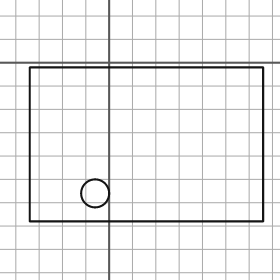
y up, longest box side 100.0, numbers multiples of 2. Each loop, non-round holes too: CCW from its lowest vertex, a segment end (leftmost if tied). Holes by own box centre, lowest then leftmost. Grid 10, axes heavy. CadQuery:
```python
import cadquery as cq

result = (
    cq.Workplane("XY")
    .moveTo(-34.0, -68.0)
    .lineTo(66.0, -68.0)
    .lineTo(66.0, -2.0)
    .lineTo(-34.0, -2.0)
    .close()
    .moveTo(-6.0, -56.0)
    .circle(6.0)
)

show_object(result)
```